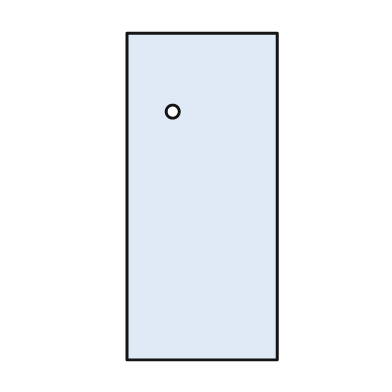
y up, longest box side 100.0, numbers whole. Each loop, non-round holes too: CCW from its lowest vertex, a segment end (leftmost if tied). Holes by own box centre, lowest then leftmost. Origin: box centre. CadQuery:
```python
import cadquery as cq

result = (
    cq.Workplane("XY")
    .moveTo(-23.0, -50.0)
    .lineTo(23.0, -50.0)
    .lineTo(23.0, 50.0)
    .lineTo(-23.0, 50.0)
    .close()
    .moveTo(-9.0, 26.0)
    .circle(2.0)
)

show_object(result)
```